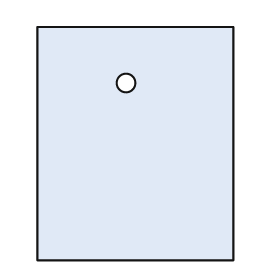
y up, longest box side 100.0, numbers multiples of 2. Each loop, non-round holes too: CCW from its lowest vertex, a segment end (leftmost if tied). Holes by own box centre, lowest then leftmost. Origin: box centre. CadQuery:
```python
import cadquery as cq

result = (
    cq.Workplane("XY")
    .moveTo(-42.0, -50.0)
    .lineTo(42.0, -50.0)
    .lineTo(42.0, 50.0)
    .lineTo(-42.0, 50.0)
    .close()
    .moveTo(-4.0, 26.0)
    .circle(4.0)
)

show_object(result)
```